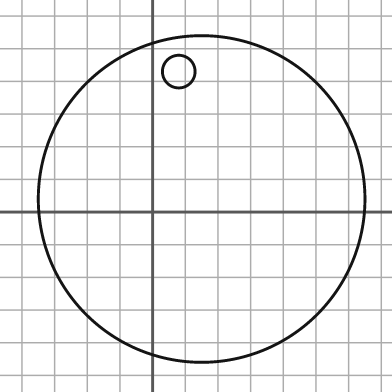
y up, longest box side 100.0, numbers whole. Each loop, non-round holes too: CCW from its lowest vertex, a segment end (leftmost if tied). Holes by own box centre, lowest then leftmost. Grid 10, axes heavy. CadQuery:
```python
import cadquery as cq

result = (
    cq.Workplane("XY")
    .moveTo(15.0, 4.0)
    .circle(50.0)
    .moveTo(8.0, 43.0)
    .circle(5.0)
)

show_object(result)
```